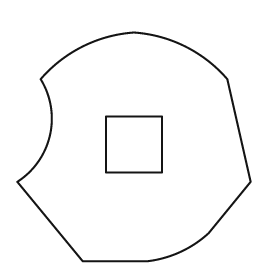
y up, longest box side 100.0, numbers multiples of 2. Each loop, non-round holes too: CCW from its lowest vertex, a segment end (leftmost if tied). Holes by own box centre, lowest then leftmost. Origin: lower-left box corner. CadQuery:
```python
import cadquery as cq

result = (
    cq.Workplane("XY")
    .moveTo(28.0, 0.0)
    .lineTo(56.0, 0.0)
    .threePointArc((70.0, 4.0), (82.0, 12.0))
    .lineTo(100.0, 34.0)
    .lineTo(90.0, 78.0)
    .threePointArc((72.0, 92.0), (50.0, 98.0))
    .threePointArc((28.0, 92.0), (10.0, 78.0))
    .threePointArc((14.0, 54.0), (0.0, 34.0))
    .close()
    .moveTo(38.0, 38.0)
    .lineTo(62.0, 38.0)
    .lineTo(62.0, 62.0)
    .lineTo(38.0, 62.0)
    .close()
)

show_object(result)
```